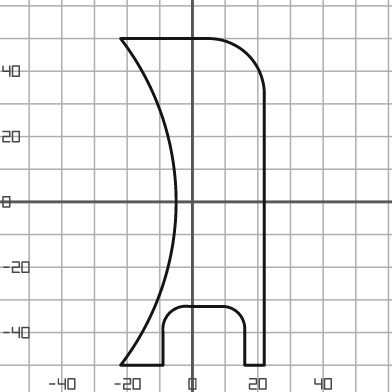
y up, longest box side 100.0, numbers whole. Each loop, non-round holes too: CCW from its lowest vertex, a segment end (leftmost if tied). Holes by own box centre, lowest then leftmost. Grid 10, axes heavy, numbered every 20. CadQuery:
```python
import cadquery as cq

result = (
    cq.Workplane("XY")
    .moveTo(-22.0, -50.0)
    .lineTo(-9.0, -50.0)
    .lineTo(-9.0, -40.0)
    .threePointArc((-7.0, -34.0), (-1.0, -32.0))
    .lineTo(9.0, -32.0)
    .threePointArc((14.0, -34.0), (16.0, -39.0))
    .lineTo(16.0, -50.0)
    .lineTo(22.0, -50.0)
    .lineTo(22.0, 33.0)
    .threePointArc((17.0, 45.0), (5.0, 50.0))
    .lineTo(-22.0, 50.0)
    .threePointArc((-5.0, 0.0), (-22.0, -50.0))
    .close()
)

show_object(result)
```